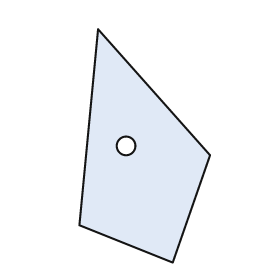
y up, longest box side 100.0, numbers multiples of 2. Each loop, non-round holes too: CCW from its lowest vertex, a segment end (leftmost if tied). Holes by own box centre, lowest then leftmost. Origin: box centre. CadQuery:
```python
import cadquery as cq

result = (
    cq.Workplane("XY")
    .moveTo(12.0, -50.0)
    .lineTo(28.0, -4.0)
    .lineTo(-20.0, 50.0)
    .lineTo(-28.0, -34.0)
    .close()
    .moveTo(-8.0, 0.0)
    .circle(4.0)
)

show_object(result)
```